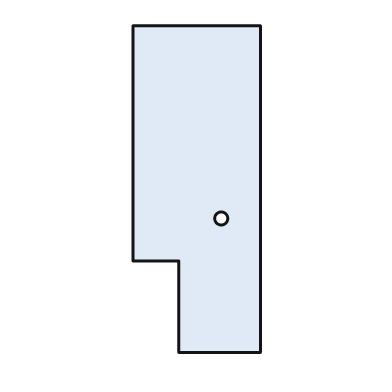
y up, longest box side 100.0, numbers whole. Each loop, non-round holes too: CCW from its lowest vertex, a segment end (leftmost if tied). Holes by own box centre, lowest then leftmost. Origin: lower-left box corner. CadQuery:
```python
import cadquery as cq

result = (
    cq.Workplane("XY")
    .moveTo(14.0, 0.0)
    .lineTo(39.0, 0.0)
    .lineTo(39.0, 100.0)
    .lineTo(0.0, 100.0)
    .lineTo(0.0, 28.0)
    .lineTo(14.0, 28.0)
    .close()
    .moveTo(27.0, 41.0)
    .circle(2.0)
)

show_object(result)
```